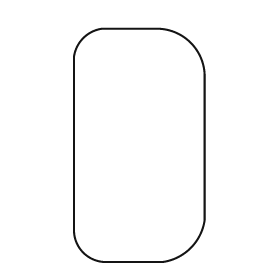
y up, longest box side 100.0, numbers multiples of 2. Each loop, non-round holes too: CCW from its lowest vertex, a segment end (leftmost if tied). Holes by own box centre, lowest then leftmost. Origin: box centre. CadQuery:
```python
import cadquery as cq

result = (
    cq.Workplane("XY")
    .moveTo(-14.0, -50.0)
    .lineTo(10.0, -50.0)
    .threePointArc((22.0, -44.0), (28.0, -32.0))
    .lineTo(28.0, 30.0)
    .threePointArc((22.0, 44.0), (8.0, 50.0))
    .lineTo(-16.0, 50.0)
    .threePointArc((-24.0, 46.0), (-28.0, 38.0))
    .lineTo(-28.0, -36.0)
    .threePointArc((-24.0, -46.0), (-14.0, -50.0))
    .close()
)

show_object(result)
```